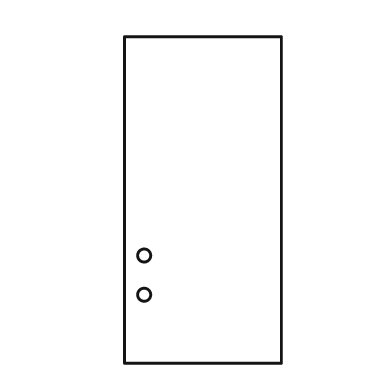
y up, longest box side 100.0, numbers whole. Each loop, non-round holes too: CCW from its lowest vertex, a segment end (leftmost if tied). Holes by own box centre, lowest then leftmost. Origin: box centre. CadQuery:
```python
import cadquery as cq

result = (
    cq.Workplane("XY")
    .moveTo(-24.0, -50.0)
    .lineTo(24.0, -50.0)
    .lineTo(24.0, 50.0)
    .lineTo(-24.0, 50.0)
    .close()
    .moveTo(-18.0, -29.0)
    .circle(2.0)
    .moveTo(-18.0, -17.0)
    .circle(2.0)
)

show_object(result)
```